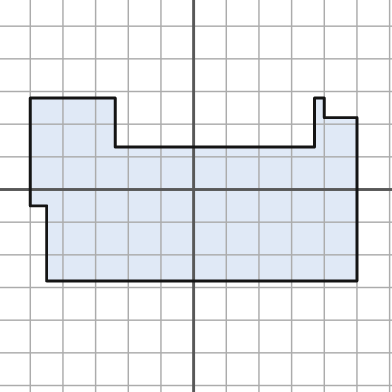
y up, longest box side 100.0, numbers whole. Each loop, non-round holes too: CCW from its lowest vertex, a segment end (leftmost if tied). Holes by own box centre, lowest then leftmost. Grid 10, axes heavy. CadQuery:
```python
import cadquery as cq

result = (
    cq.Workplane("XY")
    .moveTo(-45.0, -28.0)
    .lineTo(50.0, -28.0)
    .lineTo(50.0, 22.0)
    .lineTo(40.0, 22.0)
    .lineTo(40.0, 28.0)
    .lineTo(37.0, 28.0)
    .lineTo(37.0, 13.0)
    .lineTo(-24.0, 13.0)
    .lineTo(-24.0, 28.0)
    .lineTo(-50.0, 28.0)
    .lineTo(-50.0, -5.0)
    .lineTo(-45.0, -5.0)
    .close()
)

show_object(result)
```